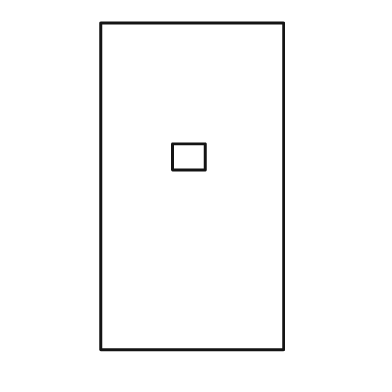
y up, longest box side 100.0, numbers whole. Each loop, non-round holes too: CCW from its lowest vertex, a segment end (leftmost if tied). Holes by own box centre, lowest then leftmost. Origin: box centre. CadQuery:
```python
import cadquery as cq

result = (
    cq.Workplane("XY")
    .moveTo(-28.0, -50.0)
    .lineTo(28.0, -50.0)
    .lineTo(28.0, 50.0)
    .lineTo(-28.0, 50.0)
    .close()
    .moveTo(-6.0, 5.0)
    .lineTo(4.0, 5.0)
    .lineTo(4.0, 13.0)
    .lineTo(-6.0, 13.0)
    .close()
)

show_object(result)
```